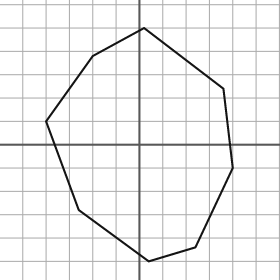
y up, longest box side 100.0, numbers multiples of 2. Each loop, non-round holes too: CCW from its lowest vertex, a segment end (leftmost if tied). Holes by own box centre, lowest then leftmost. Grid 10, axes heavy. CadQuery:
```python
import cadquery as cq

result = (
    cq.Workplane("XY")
    .moveTo(4.0, -50.0)
    .lineTo(24.0, -44.0)
    .lineTo(40.0, -10.0)
    .lineTo(36.0, 24.0)
    .lineTo(2.0, 50.0)
    .lineTo(-20.0, 38.0)
    .lineTo(-40.0, 10.0)
    .lineTo(-26.0, -28.0)
    .close()
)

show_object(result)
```